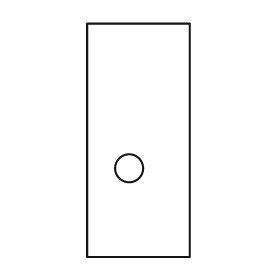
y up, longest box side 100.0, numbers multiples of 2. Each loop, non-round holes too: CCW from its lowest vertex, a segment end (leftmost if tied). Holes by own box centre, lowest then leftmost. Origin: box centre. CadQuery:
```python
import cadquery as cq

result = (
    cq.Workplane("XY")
    .moveTo(-22.0, -50.0)
    .lineTo(22.0, -50.0)
    .lineTo(22.0, 50.0)
    .lineTo(-22.0, 50.0)
    .close()
    .moveTo(-4.0, -12.0)
    .circle(6.0)
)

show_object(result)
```